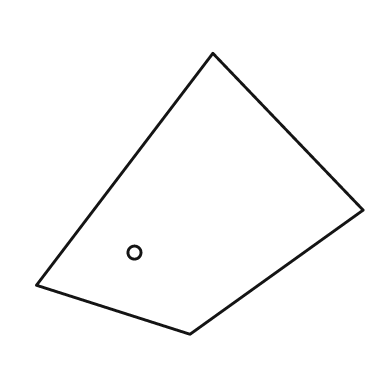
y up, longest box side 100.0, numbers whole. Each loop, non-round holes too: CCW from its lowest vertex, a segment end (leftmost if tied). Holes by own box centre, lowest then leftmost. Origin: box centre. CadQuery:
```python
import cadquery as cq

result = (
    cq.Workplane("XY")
    .moveTo(-3.0, -43.0)
    .lineTo(50.0, -5.0)
    .lineTo(4.0, 43.0)
    .lineTo(-50.0, -28.0)
    .close()
    .moveTo(-20.0, -18.0)
    .circle(2.0)
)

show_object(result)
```